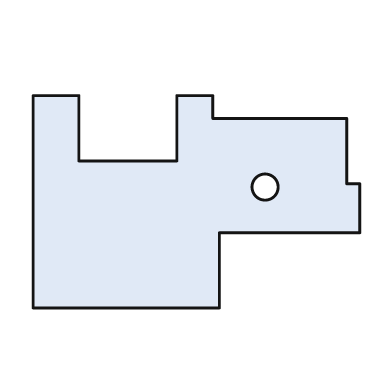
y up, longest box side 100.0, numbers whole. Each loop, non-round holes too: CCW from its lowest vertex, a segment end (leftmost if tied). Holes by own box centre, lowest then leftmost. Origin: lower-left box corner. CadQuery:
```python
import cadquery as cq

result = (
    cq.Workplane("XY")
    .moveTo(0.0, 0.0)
    .lineTo(57.0, 0.0)
    .lineTo(57.0, 23.0)
    .lineTo(100.0, 23.0)
    .lineTo(100.0, 38.0)
    .lineTo(96.0, 38.0)
    .lineTo(96.0, 58.0)
    .lineTo(55.0, 58.0)
    .lineTo(55.0, 65.0)
    .lineTo(44.0, 65.0)
    .lineTo(44.0, 45.0)
    .lineTo(14.0, 45.0)
    .lineTo(14.0, 65.0)
    .lineTo(0.0, 65.0)
    .close()
    .moveTo(71.0, 37.0)
    .circle(4.0)
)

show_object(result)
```